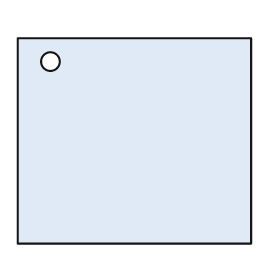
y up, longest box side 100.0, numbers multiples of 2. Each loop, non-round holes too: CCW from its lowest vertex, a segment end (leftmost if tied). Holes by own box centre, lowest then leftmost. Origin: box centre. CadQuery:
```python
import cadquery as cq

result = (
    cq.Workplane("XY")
    .moveTo(-50.0, -44.0)
    .lineTo(50.0, -44.0)
    .lineTo(50.0, 44.0)
    .lineTo(-50.0, 44.0)
    .close()
    .moveTo(-36.0, 34.0)
    .circle(4.0)
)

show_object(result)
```